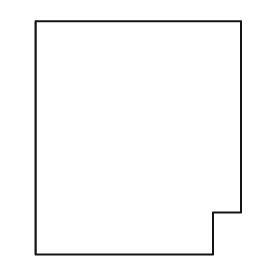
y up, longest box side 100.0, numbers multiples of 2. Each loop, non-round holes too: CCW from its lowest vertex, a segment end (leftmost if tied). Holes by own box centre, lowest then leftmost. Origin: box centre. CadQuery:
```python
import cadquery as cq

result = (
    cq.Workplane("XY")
    .moveTo(-44.0, -50.0)
    .lineTo(32.0, -50.0)
    .lineTo(32.0, -32.0)
    .lineTo(44.0, -32.0)
    .lineTo(44.0, 50.0)
    .lineTo(-44.0, 50.0)
    .close()
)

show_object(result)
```